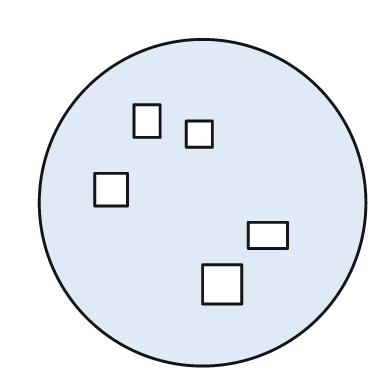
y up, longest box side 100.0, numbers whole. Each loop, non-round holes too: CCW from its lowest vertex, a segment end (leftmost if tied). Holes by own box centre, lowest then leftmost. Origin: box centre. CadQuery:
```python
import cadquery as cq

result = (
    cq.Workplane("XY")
    .moveTo(0.0, 0.0)
    .circle(50.0)
    .moveTo(0.0, -31.0)
    .lineTo(12.0, -31.0)
    .lineTo(12.0, -19.0)
    .lineTo(0.0, -19.0)
    .close()
    .moveTo(14.0, -14.0)
    .lineTo(26.0, -14.0)
    .lineTo(26.0, -6.0)
    .lineTo(14.0, -6.0)
    .close()
    .moveTo(-33.0, -1.0)
    .lineTo(-23.0, -1.0)
    .lineTo(-23.0, 9.0)
    .lineTo(-33.0, 9.0)
    .close()
    .moveTo(-5.0, 17.0)
    .lineTo(3.0, 17.0)
    .lineTo(3.0, 25.0)
    .lineTo(-5.0, 25.0)
    .close()
    .moveTo(-21.0, 20.0)
    .lineTo(-13.0, 20.0)
    .lineTo(-13.0, 30.0)
    .lineTo(-21.0, 30.0)
    .close()
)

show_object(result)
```